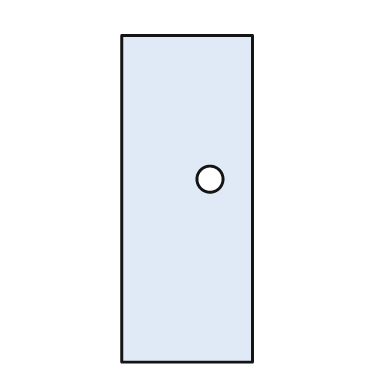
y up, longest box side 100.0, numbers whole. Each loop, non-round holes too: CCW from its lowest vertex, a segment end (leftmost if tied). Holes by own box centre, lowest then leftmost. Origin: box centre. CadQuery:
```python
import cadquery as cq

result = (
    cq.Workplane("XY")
    .moveTo(-20.0, -50.0)
    .lineTo(20.0, -50.0)
    .lineTo(20.0, 50.0)
    .lineTo(-20.0, 50.0)
    .close()
    .moveTo(7.0, 6.0)
    .circle(4.0)
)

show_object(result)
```